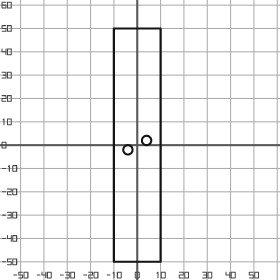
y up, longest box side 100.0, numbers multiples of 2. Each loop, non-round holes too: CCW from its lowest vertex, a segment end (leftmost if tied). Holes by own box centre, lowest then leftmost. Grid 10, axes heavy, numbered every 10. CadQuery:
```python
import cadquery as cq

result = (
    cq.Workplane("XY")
    .moveTo(-10.0, -50.0)
    .lineTo(10.0, -50.0)
    .lineTo(10.0, 50.0)
    .lineTo(-10.0, 50.0)
    .close()
    .moveTo(-4.0, -2.0)
    .circle(2.0)
    .moveTo(4.0, 2.0)
    .circle(2.0)
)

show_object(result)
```